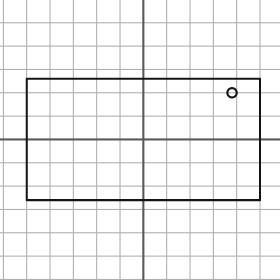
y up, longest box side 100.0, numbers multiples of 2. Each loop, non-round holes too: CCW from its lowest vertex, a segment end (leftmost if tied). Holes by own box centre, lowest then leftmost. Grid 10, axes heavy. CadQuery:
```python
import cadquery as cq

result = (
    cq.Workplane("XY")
    .moveTo(-50.0, -26.0)
    .lineTo(50.0, -26.0)
    .lineTo(50.0, 26.0)
    .lineTo(-50.0, 26.0)
    .close()
    .moveTo(38.0, 20.0)
    .circle(2.0)
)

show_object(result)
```